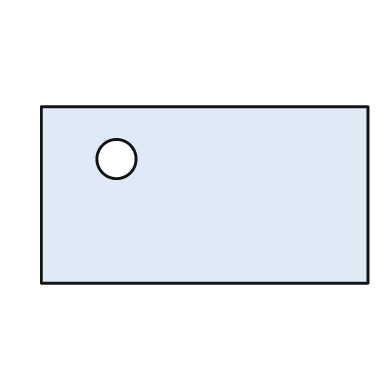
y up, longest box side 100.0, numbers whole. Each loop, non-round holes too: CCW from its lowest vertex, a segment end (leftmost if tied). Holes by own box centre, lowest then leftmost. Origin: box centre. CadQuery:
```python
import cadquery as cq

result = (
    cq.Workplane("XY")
    .moveTo(-50.0, -27.0)
    .lineTo(50.0, -27.0)
    .lineTo(50.0, 27.0)
    .lineTo(-50.0, 27.0)
    .close()
    .moveTo(-27.0, 11.0)
    .circle(6.0)
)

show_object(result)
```